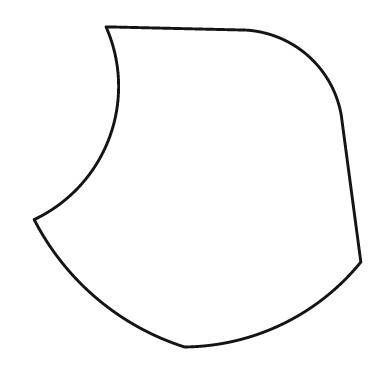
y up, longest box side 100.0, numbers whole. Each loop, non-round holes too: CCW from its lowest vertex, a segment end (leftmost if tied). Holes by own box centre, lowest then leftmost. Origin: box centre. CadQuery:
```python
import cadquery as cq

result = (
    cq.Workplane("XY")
    .moveTo(-4.0, -49.0)
    .threePointArc((26.0, -42.0), (50.0, -23.0))
    .lineTo(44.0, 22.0)
    .threePointArc((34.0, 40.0), (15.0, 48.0))
    .lineTo(-28.0, 49.0)
    .threePointArc((-27.0, 15.0), (-50.0, -10.0))
    .threePointArc((-31.0, -34.0), (-4.0, -49.0))
    .close()
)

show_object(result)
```